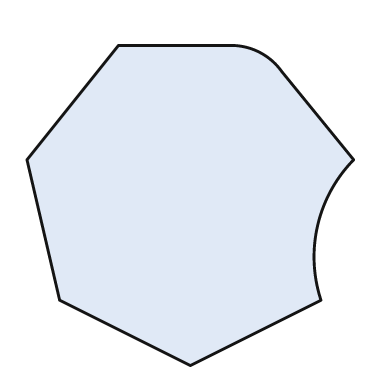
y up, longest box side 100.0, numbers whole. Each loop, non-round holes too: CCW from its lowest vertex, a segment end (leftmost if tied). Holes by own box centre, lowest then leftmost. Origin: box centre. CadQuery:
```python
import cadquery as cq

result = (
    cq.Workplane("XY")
    .moveTo(0.0, -49.0)
    .lineTo(40.0, -29.0)
    .threePointArc((39.0, -6.0), (50.0, 14.0))
    .lineTo(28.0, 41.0)
    .threePointArc((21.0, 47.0), (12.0, 49.0))
    .lineTo(-22.0, 49.0)
    .lineTo(-50.0, 14.0)
    .lineTo(-40.0, -29.0)
    .close()
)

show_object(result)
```